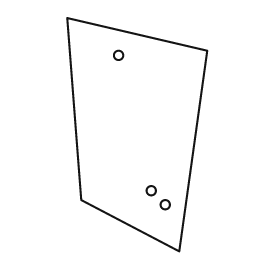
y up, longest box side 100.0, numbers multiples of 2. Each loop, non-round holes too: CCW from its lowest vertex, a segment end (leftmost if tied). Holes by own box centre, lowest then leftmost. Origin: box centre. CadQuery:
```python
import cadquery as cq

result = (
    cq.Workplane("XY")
    .moveTo(18.0, -50.0)
    .lineTo(30.0, 36.0)
    .lineTo(-30.0, 50.0)
    .lineTo(-24.0, -28.0)
    .close()
    .moveTo(12.0, -30.0)
    .circle(2.0)
    .moveTo(6.0, -24.0)
    .circle(2.0)
    .moveTo(-8.0, 34.0)
    .circle(2.0)
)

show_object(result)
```